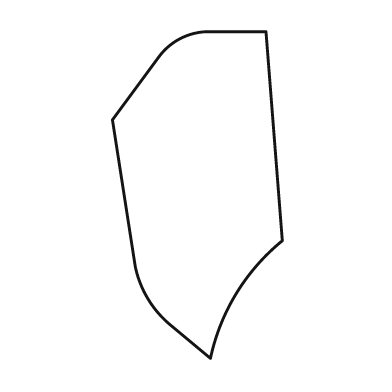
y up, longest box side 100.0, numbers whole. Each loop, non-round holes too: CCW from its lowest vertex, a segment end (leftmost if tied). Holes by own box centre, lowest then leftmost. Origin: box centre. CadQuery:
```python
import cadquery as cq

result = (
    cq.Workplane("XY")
    .moveTo(4.0, -50.0)
    .threePointArc((12.0, -30.0), (26.0, -14.0))
    .lineTo(21.0, 50.0)
    .lineTo(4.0, 50.0)
    .threePointArc((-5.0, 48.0), (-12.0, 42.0))
    .lineTo(-26.0, 23.0)
    .lineTo(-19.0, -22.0)
    .threePointArc((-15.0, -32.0), (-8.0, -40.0))
    .close()
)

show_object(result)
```